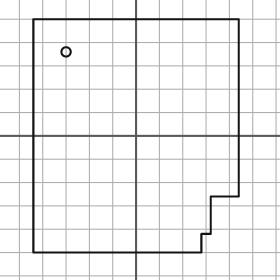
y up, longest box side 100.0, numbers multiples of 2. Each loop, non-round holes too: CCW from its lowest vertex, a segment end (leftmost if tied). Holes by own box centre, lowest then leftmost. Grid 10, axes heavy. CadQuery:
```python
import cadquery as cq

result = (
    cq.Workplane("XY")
    .moveTo(-44.0, -50.0)
    .lineTo(28.0, -50.0)
    .lineTo(28.0, -42.0)
    .lineTo(32.0, -42.0)
    .lineTo(32.0, -26.0)
    .lineTo(44.0, -26.0)
    .lineTo(44.0, 50.0)
    .lineTo(-44.0, 50.0)
    .close()
    .moveTo(-30.0, 36.0)
    .circle(2.0)
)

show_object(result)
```